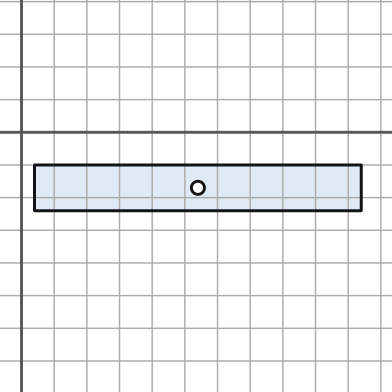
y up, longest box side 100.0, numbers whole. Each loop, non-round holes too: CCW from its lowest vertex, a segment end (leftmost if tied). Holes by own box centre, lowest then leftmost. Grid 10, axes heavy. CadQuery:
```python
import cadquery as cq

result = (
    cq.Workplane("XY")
    .moveTo(4.0, -24.0)
    .lineTo(104.0, -24.0)
    .lineTo(104.0, -10.0)
    .lineTo(4.0, -10.0)
    .close()
    .moveTo(54.0, -17.0)
    .circle(2.0)
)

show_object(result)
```